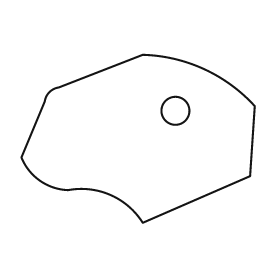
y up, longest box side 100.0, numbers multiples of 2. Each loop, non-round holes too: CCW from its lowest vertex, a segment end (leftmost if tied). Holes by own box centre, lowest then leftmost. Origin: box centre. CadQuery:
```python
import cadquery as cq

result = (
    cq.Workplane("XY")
    .moveTo(2.0, -36.0)
    .lineTo(48.0, -16.0)
    .lineTo(50.0, 14.0)
    .threePointArc((28.0, 30.0), (2.0, 36.0))
    .lineTo(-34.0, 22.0)
    .threePointArc((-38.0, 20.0), (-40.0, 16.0))
    .lineTo(-50.0, -8.0)
    .threePointArc((-42.0, -18.0), (-30.0, -22.0))
    .threePointArc((-12.0, -24.0), (2.0, -36.0))
    .close()
    .moveTo(16.0, 12.0)
    .circle(6.0)
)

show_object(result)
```